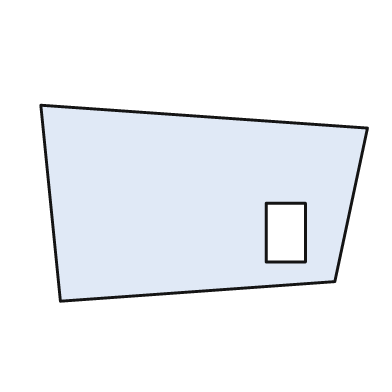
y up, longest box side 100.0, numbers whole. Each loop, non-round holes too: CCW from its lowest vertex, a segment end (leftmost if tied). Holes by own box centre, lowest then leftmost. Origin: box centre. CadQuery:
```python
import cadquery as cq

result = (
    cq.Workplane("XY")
    .moveTo(-44.0, -30.0)
    .lineTo(40.0, -24.0)
    .lineTo(50.0, 23.0)
    .lineTo(-50.0, 30.0)
    .close()
    .moveTo(19.0, -18.0)
    .lineTo(31.0, -18.0)
    .lineTo(31.0, 0.0)
    .lineTo(19.0, 0.0)
    .close()
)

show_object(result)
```